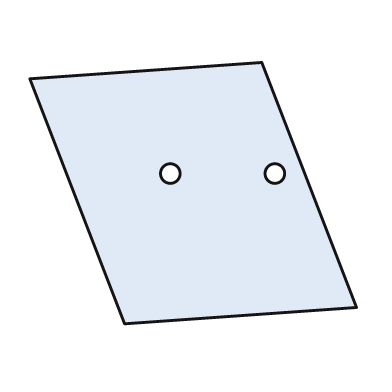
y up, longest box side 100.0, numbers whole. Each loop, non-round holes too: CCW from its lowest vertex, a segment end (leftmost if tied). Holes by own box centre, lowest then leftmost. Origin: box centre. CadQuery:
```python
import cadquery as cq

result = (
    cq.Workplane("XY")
    .moveTo(-21.0, -40.0)
    .lineTo(50.0, -35.0)
    .lineTo(21.0, 40.0)
    .lineTo(-50.0, 35.0)
    .close()
    .moveTo(-7.0, 6.0)
    .circle(3.0)
    .moveTo(25.0, 6.0)
    .circle(3.0)
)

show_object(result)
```